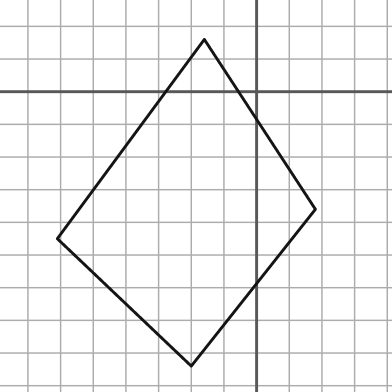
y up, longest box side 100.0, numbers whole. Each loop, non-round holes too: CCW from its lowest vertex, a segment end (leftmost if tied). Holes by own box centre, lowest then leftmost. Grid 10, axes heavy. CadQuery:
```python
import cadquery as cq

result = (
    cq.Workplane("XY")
    .moveTo(-20.0, -84.0)
    .lineTo(18.0, -36.0)
    .lineTo(-16.0, 16.0)
    .lineTo(-61.0, -45.0)
    .close()
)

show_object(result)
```